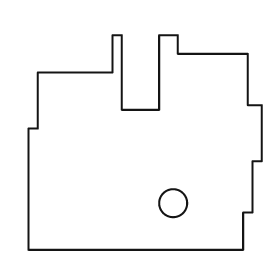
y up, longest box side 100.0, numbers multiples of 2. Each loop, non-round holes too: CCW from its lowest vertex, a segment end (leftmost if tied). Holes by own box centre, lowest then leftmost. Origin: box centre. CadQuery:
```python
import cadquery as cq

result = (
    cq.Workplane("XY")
    .moveTo(-50.0, -46.0)
    .lineTo(42.0, -46.0)
    .lineTo(42.0, -30.0)
    .lineTo(46.0, -30.0)
    .lineTo(46.0, -8.0)
    .lineTo(50.0, -8.0)
    .lineTo(50.0, 16.0)
    .lineTo(44.0, 16.0)
    .lineTo(44.0, 38.0)
    .lineTo(14.0, 38.0)
    .lineTo(14.0, 46.0)
    .lineTo(6.0, 46.0)
    .lineTo(6.0, 14.0)
    .lineTo(-10.0, 14.0)
    .lineTo(-10.0, 46.0)
    .lineTo(-14.0, 46.0)
    .lineTo(-14.0, 30.0)
    .lineTo(-46.0, 30.0)
    .lineTo(-46.0, 6.0)
    .lineTo(-50.0, 6.0)
    .close()
    .moveTo(12.0, -26.0)
    .circle(6.0)
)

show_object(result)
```